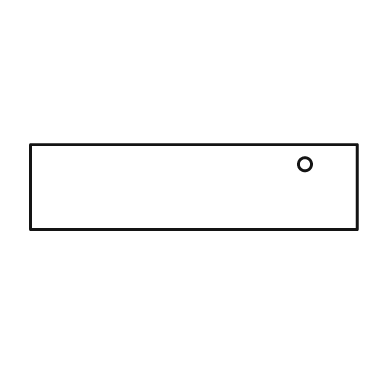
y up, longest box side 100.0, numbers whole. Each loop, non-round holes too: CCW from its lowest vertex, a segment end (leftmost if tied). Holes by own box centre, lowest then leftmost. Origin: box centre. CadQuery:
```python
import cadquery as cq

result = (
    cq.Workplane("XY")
    .moveTo(-50.0, -13.0)
    .lineTo(50.0, -13.0)
    .lineTo(50.0, 13.0)
    .lineTo(-50.0, 13.0)
    .close()
    .moveTo(34.0, 7.0)
    .circle(2.0)
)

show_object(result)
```